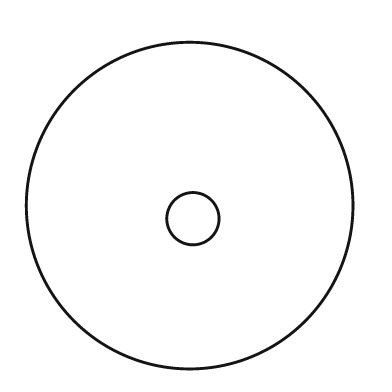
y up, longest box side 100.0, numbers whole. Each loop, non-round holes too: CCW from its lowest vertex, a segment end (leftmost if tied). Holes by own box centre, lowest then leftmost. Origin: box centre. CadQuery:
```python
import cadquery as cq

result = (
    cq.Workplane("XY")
    .moveTo(0.0, 0.0)
    .circle(50.0)
    .moveTo(1.0, -4.0)
    .circle(8.0)
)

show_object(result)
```